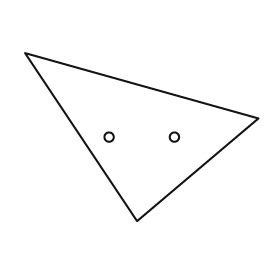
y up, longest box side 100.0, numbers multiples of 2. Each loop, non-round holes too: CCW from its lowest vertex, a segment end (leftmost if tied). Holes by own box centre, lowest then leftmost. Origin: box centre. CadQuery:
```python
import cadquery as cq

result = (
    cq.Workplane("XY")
    .moveTo(-2.0, -36.0)
    .lineTo(50.0, 8.0)
    .lineTo(-50.0, 36.0)
    .close()
    .moveTo(-14.0, 0.0)
    .circle(2.0)
    .moveTo(14.0, 0.0)
    .circle(2.0)
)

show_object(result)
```